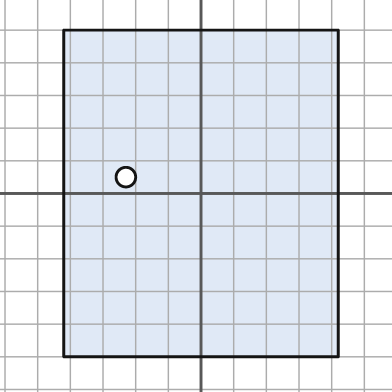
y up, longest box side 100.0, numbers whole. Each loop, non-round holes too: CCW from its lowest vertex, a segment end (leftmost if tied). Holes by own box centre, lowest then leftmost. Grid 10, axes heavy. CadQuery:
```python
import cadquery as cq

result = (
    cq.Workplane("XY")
    .moveTo(-42.0, -50.0)
    .lineTo(42.0, -50.0)
    .lineTo(42.0, 50.0)
    .lineTo(-42.0, 50.0)
    .close()
    .moveTo(-23.0, 5.0)
    .circle(3.0)
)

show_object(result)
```